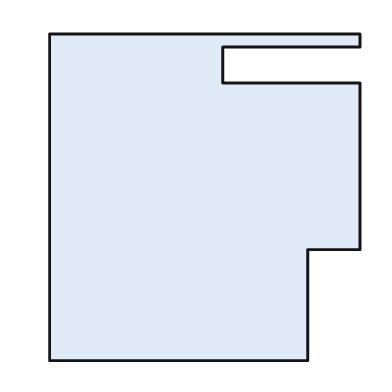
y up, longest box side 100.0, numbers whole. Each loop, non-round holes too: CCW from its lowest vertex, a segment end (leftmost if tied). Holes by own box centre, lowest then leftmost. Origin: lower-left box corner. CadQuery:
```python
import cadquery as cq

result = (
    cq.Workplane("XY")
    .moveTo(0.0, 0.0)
    .lineTo(79.0, 0.0)
    .lineTo(79.0, 34.0)
    .lineTo(95.0, 34.0)
    .lineTo(95.0, 85.0)
    .lineTo(53.0, 85.0)
    .lineTo(53.0, 96.0)
    .lineTo(95.0, 96.0)
    .lineTo(95.0, 100.0)
    .lineTo(0.0, 100.0)
    .close()
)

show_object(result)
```